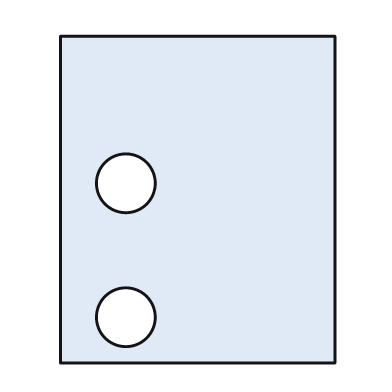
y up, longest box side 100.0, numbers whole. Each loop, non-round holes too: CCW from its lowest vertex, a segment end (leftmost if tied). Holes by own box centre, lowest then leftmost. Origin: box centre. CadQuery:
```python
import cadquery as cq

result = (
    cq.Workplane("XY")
    .moveTo(-42.0, -50.0)
    .lineTo(42.0, -50.0)
    .lineTo(42.0, 50.0)
    .lineTo(-42.0, 50.0)
    .close()
    .moveTo(-22.0, -36.0)
    .circle(9.0)
    .moveTo(-22.0, 5.0)
    .circle(9.0)
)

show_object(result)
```